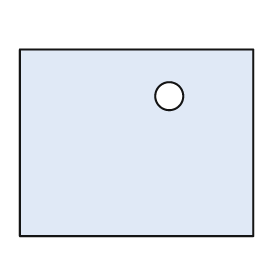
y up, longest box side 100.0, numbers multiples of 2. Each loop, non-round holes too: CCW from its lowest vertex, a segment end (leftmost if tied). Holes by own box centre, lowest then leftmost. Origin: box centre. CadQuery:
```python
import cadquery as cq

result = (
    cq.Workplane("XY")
    .moveTo(-50.0, -40.0)
    .lineTo(50.0, -40.0)
    .lineTo(50.0, 40.0)
    .lineTo(-50.0, 40.0)
    .close()
    .moveTo(14.0, 20.0)
    .circle(6.0)
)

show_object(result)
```